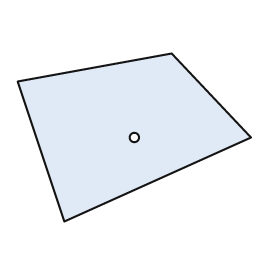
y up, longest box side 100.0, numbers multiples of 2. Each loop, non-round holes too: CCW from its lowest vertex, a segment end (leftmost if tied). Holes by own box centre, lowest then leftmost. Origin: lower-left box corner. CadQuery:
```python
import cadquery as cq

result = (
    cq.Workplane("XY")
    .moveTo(20.0, 0.0)
    .lineTo(100.0, 36.0)
    .lineTo(66.0, 72.0)
    .lineTo(0.0, 60.0)
    .close()
    .moveTo(50.0, 36.0)
    .circle(2.0)
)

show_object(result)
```